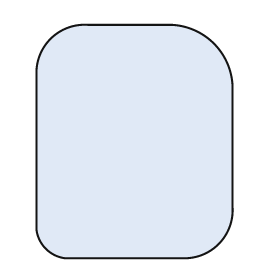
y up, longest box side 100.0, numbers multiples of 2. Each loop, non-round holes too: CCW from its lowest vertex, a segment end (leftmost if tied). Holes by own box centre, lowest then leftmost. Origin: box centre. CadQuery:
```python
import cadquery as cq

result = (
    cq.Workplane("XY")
    .moveTo(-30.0, -50.0)
    .lineTo(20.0, -50.0)
    .threePointArc((36.0, -44.0), (42.0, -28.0))
    .lineTo(42.0, 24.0)
    .threePointArc((34.0, 42.0), (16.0, 50.0))
    .lineTo(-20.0, 50.0)
    .threePointArc((-36.0, 44.0), (-42.0, 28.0))
    .lineTo(-42.0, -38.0)
    .threePointArc((-38.0, -46.0), (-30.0, -50.0))
    .close()
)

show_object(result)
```